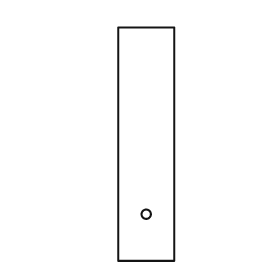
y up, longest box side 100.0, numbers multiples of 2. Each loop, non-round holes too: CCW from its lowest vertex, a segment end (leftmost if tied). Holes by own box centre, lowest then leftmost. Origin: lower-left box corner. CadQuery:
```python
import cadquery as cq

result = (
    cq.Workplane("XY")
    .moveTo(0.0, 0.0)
    .lineTo(24.0, 0.0)
    .lineTo(24.0, 100.0)
    .lineTo(0.0, 100.0)
    .close()
    .moveTo(12.0, 20.0)
    .circle(2.0)
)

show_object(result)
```